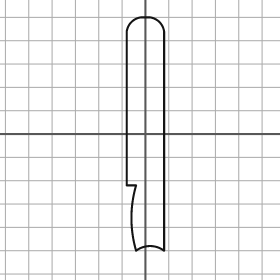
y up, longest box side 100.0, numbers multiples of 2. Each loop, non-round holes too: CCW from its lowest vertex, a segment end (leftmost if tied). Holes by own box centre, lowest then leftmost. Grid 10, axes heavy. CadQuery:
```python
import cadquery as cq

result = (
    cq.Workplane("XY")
    .moveTo(-4.0, -50.0)
    .threePointArc((2.0, -48.0), (8.0, -50.0))
    .lineTo(8.0, 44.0)
    .threePointArc((6.0, 48.0), (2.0, 50.0))
    .lineTo(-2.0, 50.0)
    .threePointArc((-6.0, 48.0), (-8.0, 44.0))
    .lineTo(-8.0, -22.0)
    .lineTo(-4.0, -22.0)
    .threePointArc((-6.0, -36.0), (-4.0, -50.0))
    .close()
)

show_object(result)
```